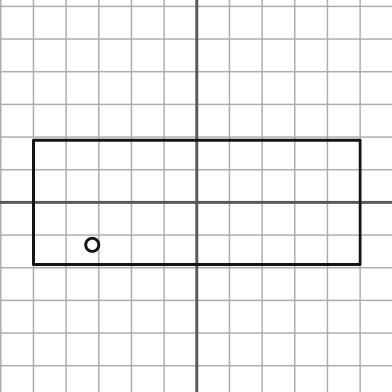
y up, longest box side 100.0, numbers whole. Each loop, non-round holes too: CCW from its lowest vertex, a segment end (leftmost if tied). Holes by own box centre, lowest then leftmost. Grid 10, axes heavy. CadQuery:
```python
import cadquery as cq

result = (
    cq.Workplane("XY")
    .moveTo(-50.0, -19.0)
    .lineTo(50.0, -19.0)
    .lineTo(50.0, 19.0)
    .lineTo(-50.0, 19.0)
    .close()
    .moveTo(-32.0, -13.0)
    .circle(2.0)
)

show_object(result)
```